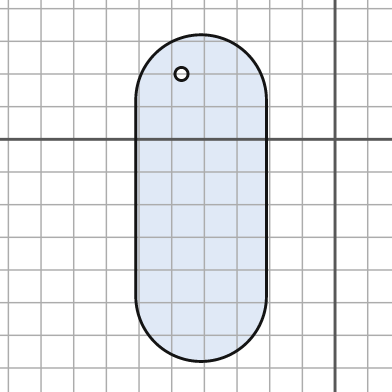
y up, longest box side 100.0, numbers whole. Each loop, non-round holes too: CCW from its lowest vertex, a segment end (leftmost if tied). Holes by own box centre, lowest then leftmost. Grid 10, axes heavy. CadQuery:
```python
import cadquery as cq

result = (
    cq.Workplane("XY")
    .moveTo(-61.0, -48.0)
    .threePointArc((-41.0, -68.0), (-21.0, -48.0))
    .lineTo(-21.0, 12.0)
    .threePointArc((-41.0, 32.0), (-61.0, 12.0))
    .close()
    .moveTo(-47.0, 20.0)
    .circle(2.0)
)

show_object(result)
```